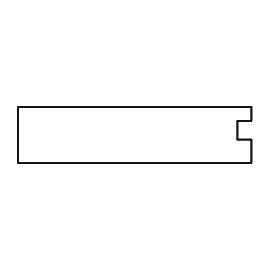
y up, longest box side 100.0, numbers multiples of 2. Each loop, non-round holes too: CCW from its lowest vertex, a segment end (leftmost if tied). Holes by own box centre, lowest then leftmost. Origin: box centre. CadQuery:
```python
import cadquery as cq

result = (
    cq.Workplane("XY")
    .moveTo(-50.0, -12.0)
    .lineTo(50.0, -12.0)
    .lineTo(50.0, -2.0)
    .lineTo(44.0, -2.0)
    .lineTo(44.0, 6.0)
    .lineTo(50.0, 6.0)
    .lineTo(50.0, 12.0)
    .lineTo(-50.0, 12.0)
    .close()
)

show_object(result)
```